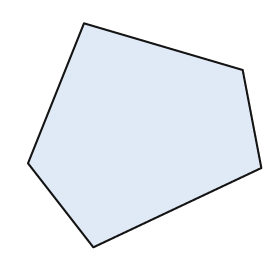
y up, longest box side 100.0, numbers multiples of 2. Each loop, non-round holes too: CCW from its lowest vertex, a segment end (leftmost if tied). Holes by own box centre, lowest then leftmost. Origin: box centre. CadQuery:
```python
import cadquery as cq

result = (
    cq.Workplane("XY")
    .moveTo(-22.0, -48.0)
    .lineTo(50.0, -14.0)
    .lineTo(42.0, 28.0)
    .lineTo(-26.0, 48.0)
    .lineTo(-50.0, -12.0)
    .close()
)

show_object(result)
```